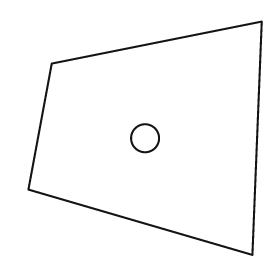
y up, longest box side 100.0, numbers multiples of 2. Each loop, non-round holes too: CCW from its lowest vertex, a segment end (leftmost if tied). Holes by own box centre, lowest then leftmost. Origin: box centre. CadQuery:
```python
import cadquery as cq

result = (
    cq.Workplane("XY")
    .moveTo(46.0, -50.0)
    .lineTo(50.0, 50.0)
    .lineTo(-40.0, 32.0)
    .lineTo(-50.0, -22.0)
    .close()
    .moveTo(0.0, 0.0)
    .circle(6.0)
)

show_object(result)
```